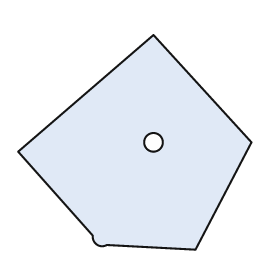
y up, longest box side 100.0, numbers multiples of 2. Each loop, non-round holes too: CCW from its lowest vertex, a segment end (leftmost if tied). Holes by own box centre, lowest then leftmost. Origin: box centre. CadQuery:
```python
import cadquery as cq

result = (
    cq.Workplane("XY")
    .moveTo(26.0, -46.0)
    .lineTo(50.0, 0.0)
    .lineTo(8.0, 46.0)
    .lineTo(-50.0, -4.0)
    .lineTo(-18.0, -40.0)
    .threePointArc((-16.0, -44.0), (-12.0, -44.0))
    .close()
    .moveTo(8.0, 0.0)
    .circle(4.0)
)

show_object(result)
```